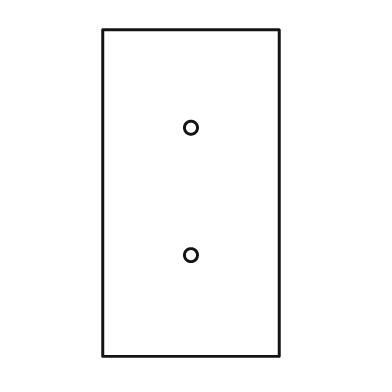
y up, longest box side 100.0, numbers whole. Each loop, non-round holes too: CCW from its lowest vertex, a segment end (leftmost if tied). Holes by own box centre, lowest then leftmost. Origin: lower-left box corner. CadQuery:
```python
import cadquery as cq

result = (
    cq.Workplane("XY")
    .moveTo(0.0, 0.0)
    .lineTo(54.0, 0.0)
    .lineTo(54.0, 100.0)
    .lineTo(0.0, 100.0)
    .close()
    .moveTo(27.0, 31.0)
    .circle(2.0)
    .moveTo(27.0, 70.0)
    .circle(2.0)
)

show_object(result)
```